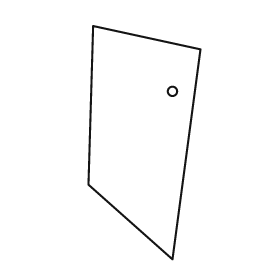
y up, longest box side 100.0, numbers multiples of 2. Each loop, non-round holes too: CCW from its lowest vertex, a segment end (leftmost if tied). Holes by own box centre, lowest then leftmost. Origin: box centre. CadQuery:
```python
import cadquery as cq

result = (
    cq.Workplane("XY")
    .moveTo(12.0, -50.0)
    .lineTo(24.0, 40.0)
    .lineTo(-22.0, 50.0)
    .lineTo(-24.0, -18.0)
    .close()
    .moveTo(12.0, 22.0)
    .circle(2.0)
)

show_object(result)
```